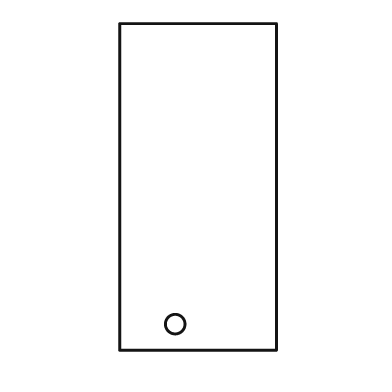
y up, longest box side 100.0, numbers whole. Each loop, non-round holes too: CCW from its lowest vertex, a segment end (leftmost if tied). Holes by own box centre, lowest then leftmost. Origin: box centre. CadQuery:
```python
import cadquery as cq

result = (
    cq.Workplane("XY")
    .moveTo(-24.0, -50.0)
    .lineTo(24.0, -50.0)
    .lineTo(24.0, 50.0)
    .lineTo(-24.0, 50.0)
    .close()
    .moveTo(-7.0, -42.0)
    .circle(3.0)
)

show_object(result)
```